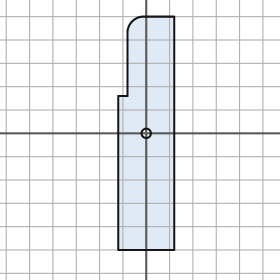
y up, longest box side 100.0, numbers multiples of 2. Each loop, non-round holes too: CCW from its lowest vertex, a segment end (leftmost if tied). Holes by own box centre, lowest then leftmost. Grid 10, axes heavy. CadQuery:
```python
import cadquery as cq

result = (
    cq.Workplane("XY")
    .moveTo(-12.0, -50.0)
    .lineTo(12.0, -50.0)
    .lineTo(12.0, 50.0)
    .lineTo(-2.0, 50.0)
    .threePointArc((-6.0, 48.0), (-8.0, 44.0))
    .lineTo(-8.0, 16.0)
    .lineTo(-12.0, 16.0)
    .close()
    .moveTo(0.0, 0.0)
    .circle(2.0)
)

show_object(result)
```